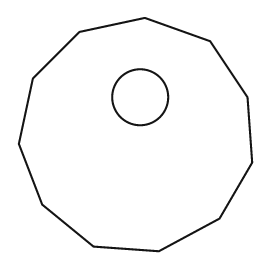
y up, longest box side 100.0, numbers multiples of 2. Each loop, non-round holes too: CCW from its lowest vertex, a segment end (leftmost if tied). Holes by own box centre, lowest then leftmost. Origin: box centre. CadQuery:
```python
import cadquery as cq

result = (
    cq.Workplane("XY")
    .moveTo(10.0, -50.0)
    .lineTo(36.0, -36.0)
    .lineTo(50.0, -12.0)
    .lineTo(48.0, 16.0)
    .lineTo(32.0, 40.0)
    .lineTo(4.0, 50.0)
    .lineTo(-24.0, 44.0)
    .lineTo(-44.0, 24.0)
    .lineTo(-50.0, -4.0)
    .lineTo(-40.0, -30.0)
    .lineTo(-18.0, -48.0)
    .close()
    .moveTo(2.0, 16.0)
    .circle(12.0)
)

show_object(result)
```